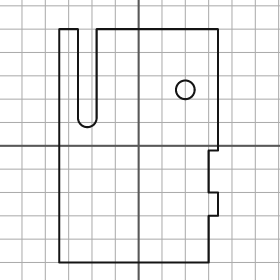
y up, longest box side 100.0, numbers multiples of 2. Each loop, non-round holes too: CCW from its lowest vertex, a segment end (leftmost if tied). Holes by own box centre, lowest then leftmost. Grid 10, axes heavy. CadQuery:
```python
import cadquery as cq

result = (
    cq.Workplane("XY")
    .moveTo(-34.0, -50.0)
    .lineTo(30.0, -50.0)
    .lineTo(30.0, -30.0)
    .lineTo(34.0, -30.0)
    .lineTo(34.0, -20.0)
    .lineTo(30.0, -20.0)
    .lineTo(30.0, -2.0)
    .lineTo(34.0, -2.0)
    .lineTo(34.0, 50.0)
    .lineTo(-18.0, 50.0)
    .lineTo(-18.0, 12.0)
    .threePointArc((-22.0, 8.0), (-26.0, 12.0))
    .lineTo(-26.0, 50.0)
    .lineTo(-34.0, 50.0)
    .close()
    .moveTo(20.0, 24.0)
    .circle(4.0)
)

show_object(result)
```